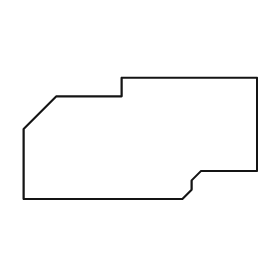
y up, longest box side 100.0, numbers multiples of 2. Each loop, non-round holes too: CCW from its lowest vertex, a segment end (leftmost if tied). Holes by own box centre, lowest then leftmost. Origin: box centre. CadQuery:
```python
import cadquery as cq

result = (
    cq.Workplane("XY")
    .moveTo(-50.0, -26.0)
    .lineTo(18.0, -26.0)
    .lineTo(22.0, -22.0)
    .lineTo(22.0, -18.0)
    .lineTo(26.0, -14.0)
    .lineTo(50.0, -14.0)
    .lineTo(50.0, 26.0)
    .lineTo(-8.0, 26.0)
    .lineTo(-8.0, 18.0)
    .lineTo(-36.0, 18.0)
    .lineTo(-50.0, 4.0)
    .close()
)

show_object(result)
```